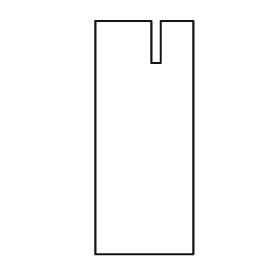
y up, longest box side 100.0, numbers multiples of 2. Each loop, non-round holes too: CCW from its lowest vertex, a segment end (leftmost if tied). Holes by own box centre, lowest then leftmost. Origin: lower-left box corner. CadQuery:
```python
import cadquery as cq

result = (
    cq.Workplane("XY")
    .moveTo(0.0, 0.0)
    .lineTo(42.0, 0.0)
    .lineTo(42.0, 100.0)
    .lineTo(28.0, 100.0)
    .lineTo(28.0, 82.0)
    .lineTo(24.0, 82.0)
    .lineTo(24.0, 100.0)
    .lineTo(0.0, 100.0)
    .close()
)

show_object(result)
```